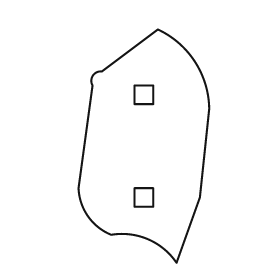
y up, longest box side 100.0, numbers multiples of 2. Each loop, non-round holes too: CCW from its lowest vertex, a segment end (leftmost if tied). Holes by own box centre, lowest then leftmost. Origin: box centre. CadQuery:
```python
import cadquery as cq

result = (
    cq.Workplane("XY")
    .moveTo(14.0, -50.0)
    .lineTo(24.0, -22.0)
    .lineTo(28.0, 16.0)
    .threePointArc((22.0, 36.0), (6.0, 50.0))
    .lineTo(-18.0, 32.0)
    .threePointArc((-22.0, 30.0), (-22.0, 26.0))
    .lineTo(-28.0, -18.0)
    .threePointArc((-24.0, -30.0), (-14.0, -38.0))
    .threePointArc((2.0, -40.0), (14.0, -50.0))
    .close()
    .moveTo(-4.0, -26.0)
    .lineTo(4.0, -26.0)
    .lineTo(4.0, -18.0)
    .lineTo(-4.0, -18.0)
    .close()
    .moveTo(-4.0, 18.0)
    .lineTo(4.0, 18.0)
    .lineTo(4.0, 26.0)
    .lineTo(-4.0, 26.0)
    .close()
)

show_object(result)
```